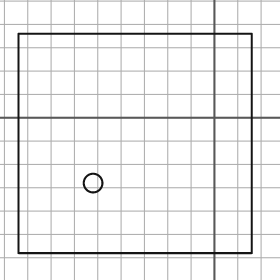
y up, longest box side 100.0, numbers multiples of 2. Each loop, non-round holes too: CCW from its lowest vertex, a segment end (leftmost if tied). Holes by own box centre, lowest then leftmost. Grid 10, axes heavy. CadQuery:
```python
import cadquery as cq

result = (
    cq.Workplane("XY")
    .moveTo(-84.0, -58.0)
    .lineTo(16.0, -58.0)
    .lineTo(16.0, 36.0)
    .lineTo(-84.0, 36.0)
    .close()
    .moveTo(-52.0, -28.0)
    .circle(4.0)
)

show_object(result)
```